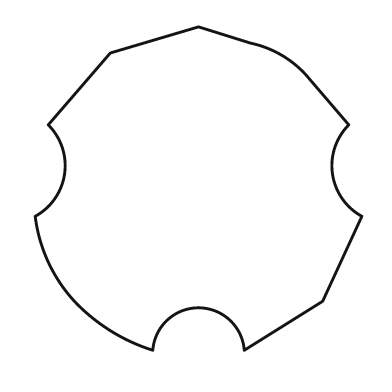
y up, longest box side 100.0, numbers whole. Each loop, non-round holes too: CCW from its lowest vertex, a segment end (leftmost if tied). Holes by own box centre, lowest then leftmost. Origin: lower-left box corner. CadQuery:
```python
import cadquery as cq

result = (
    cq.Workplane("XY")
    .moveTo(36.0, 0.0)
    .threePointArc((50.0, 13.0), (64.0, 0.0))
    .lineTo(88.0, 15.0)
    .lineTo(100.0, 41.0)
    .threePointArc((91.0, 54.0), (96.0, 69.0))
    .lineTo(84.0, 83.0)
    .threePointArc((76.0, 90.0), (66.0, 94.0))
    .lineTo(50.0, 99.0)
    .lineTo(23.0, 91.0)
    .lineTo(4.0, 69.0)
    .threePointArc((9.0, 54.0), (0.0, 41.0))
    .threePointArc((4.0, 27.0), (12.0, 15.0))
    .threePointArc((23.0, 6.0), (36.0, 0.0))
    .close()
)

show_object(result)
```